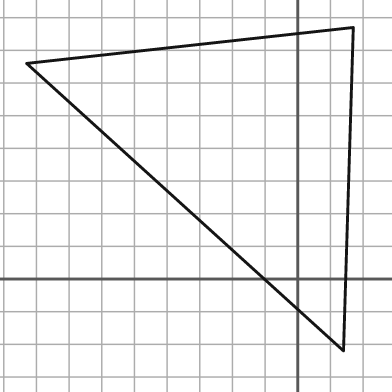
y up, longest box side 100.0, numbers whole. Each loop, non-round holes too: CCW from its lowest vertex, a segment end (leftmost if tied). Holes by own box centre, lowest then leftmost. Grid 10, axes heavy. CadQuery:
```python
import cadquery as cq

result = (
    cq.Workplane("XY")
    .moveTo(14.0, -22.0)
    .lineTo(17.0, 77.0)
    .lineTo(-83.0, 66.0)
    .close()
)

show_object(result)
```